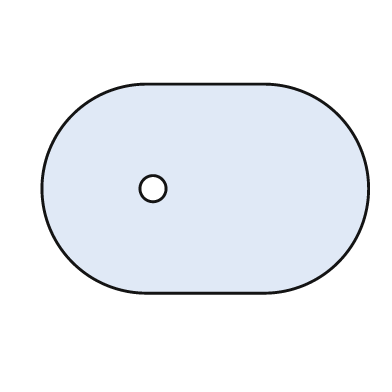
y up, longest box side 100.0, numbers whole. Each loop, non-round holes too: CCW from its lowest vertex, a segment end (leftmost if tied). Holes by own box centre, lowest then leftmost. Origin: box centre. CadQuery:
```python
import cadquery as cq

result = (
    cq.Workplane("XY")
    .moveTo(-18.0, -32.0)
    .lineTo(18.0, -32.0)
    .threePointArc((50.0, 0.0), (18.0, 32.0))
    .lineTo(-18.0, 32.0)
    .threePointArc((-50.0, 0.0), (-18.0, -32.0))
    .close()
    .moveTo(-16.0, 0.0)
    .circle(4.0)
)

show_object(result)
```